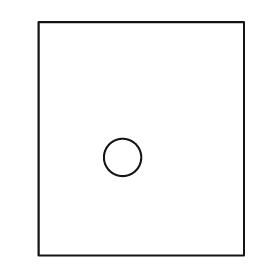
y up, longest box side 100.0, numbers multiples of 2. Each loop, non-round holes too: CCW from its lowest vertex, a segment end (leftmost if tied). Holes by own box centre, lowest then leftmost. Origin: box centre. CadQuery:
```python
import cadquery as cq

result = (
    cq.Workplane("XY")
    .moveTo(-44.0, -50.0)
    .lineTo(44.0, -50.0)
    .lineTo(44.0, 50.0)
    .lineTo(-44.0, 50.0)
    .close()
    .moveTo(-8.0, -8.0)
    .circle(8.0)
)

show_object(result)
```